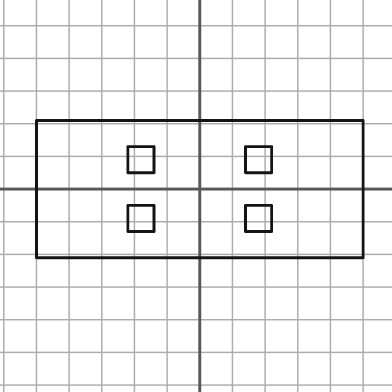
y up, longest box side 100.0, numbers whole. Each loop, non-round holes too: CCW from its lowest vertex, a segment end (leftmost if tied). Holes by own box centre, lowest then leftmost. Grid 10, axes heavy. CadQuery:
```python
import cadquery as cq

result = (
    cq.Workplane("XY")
    .moveTo(-50.0, -21.0)
    .lineTo(50.0, -21.0)
    .lineTo(50.0, 21.0)
    .lineTo(-50.0, 21.0)
    .close()
    .moveTo(-22.0, -13.0)
    .lineTo(-14.0, -13.0)
    .lineTo(-14.0, -5.0)
    .lineTo(-22.0, -5.0)
    .close()
    .moveTo(14.0, -13.0)
    .lineTo(22.0, -13.0)
    .lineTo(22.0, -5.0)
    .lineTo(14.0, -5.0)
    .close()
    .moveTo(-22.0, 5.0)
    .lineTo(-14.0, 5.0)
    .lineTo(-14.0, 13.0)
    .lineTo(-22.0, 13.0)
    .close()
    .moveTo(14.0, 5.0)
    .lineTo(22.0, 5.0)
    .lineTo(22.0, 13.0)
    .lineTo(14.0, 13.0)
    .close()
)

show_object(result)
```